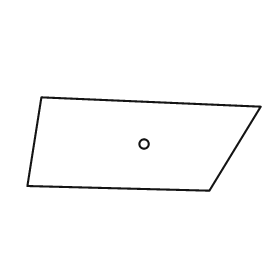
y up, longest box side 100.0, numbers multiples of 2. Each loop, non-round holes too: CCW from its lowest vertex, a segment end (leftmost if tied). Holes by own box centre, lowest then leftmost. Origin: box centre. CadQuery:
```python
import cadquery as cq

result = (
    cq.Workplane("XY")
    .moveTo(28.0, -20.0)
    .lineTo(50.0, 16.0)
    .lineTo(-44.0, 20.0)
    .lineTo(-50.0, -18.0)
    .close()
    .moveTo(0.0, 0.0)
    .circle(2.0)
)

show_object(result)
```